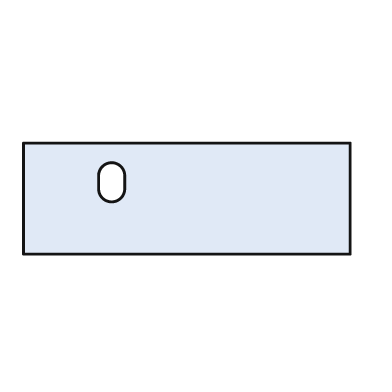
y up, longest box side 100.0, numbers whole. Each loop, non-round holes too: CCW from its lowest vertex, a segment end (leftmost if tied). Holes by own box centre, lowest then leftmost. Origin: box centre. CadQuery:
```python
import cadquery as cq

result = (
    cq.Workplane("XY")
    .moveTo(-50.0, -17.0)
    .lineTo(50.0, -17.0)
    .lineTo(50.0, 17.0)
    .lineTo(-50.0, 17.0)
    .close()
    .moveTo(-27.0, 3.0)
    .threePointArc((-23.0, -1.0), (-19.0, 3.0))
    .lineTo(-19.0, 7.0)
    .threePointArc((-23.0, 11.0), (-27.0, 7.0))
    .close()
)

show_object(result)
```